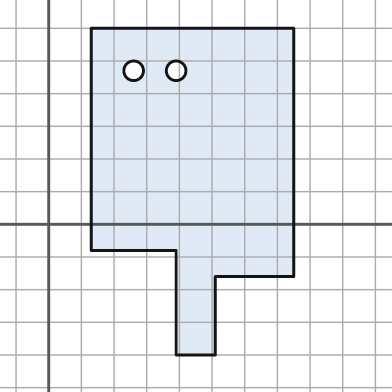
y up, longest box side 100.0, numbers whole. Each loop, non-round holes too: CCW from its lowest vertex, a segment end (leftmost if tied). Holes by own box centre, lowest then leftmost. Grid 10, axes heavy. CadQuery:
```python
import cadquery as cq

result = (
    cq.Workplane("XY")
    .moveTo(39.0, -40.0)
    .lineTo(51.0, -40.0)
    .lineTo(51.0, -16.0)
    .lineTo(75.0, -16.0)
    .lineTo(75.0, 60.0)
    .lineTo(13.0, 60.0)
    .lineTo(13.0, -8.0)
    .lineTo(39.0, -8.0)
    .close()
    .moveTo(26.0, 47.0)
    .circle(3.0)
    .moveTo(39.0, 47.0)
    .circle(3.0)
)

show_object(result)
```